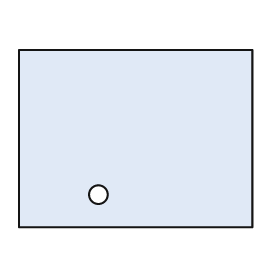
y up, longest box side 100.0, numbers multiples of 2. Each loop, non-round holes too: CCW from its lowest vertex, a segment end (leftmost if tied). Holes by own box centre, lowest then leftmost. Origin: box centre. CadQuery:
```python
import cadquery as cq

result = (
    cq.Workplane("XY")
    .moveTo(-50.0, -38.0)
    .lineTo(50.0, -38.0)
    .lineTo(50.0, 38.0)
    .lineTo(-50.0, 38.0)
    .close()
    .moveTo(-16.0, -24.0)
    .circle(4.0)
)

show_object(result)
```